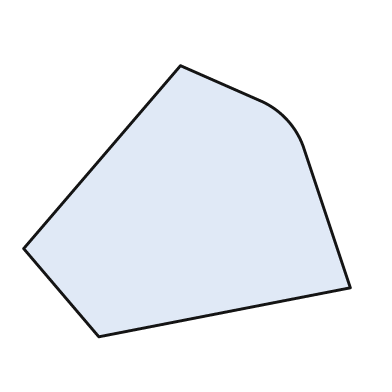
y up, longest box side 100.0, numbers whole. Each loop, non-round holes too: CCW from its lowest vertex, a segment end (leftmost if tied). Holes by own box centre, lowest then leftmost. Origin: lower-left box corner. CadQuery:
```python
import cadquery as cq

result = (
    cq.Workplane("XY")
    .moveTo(23.0, 0.0)
    .lineTo(100.0, 15.0)
    .lineTo(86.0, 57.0)
    .threePointArc((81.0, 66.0), (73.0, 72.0))
    .lineTo(48.0, 83.0)
    .lineTo(0.0, 27.0)
    .close()
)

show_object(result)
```